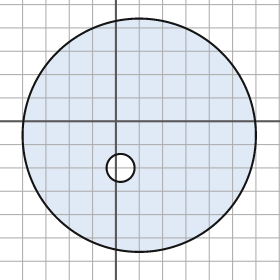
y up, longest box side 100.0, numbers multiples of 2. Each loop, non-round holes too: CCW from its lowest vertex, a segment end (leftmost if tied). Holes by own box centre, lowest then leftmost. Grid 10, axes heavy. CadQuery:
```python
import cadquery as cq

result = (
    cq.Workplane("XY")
    .moveTo(10.0, -6.0)
    .circle(50.0)
    .moveTo(2.0, -20.0)
    .circle(6.0)
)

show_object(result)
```